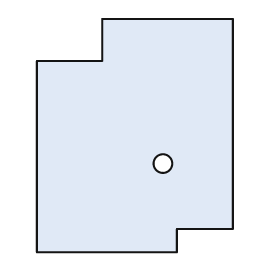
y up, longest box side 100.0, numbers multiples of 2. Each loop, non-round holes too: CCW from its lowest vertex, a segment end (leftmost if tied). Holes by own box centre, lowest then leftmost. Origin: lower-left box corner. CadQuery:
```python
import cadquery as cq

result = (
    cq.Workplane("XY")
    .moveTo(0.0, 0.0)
    .lineTo(60.0, 0.0)
    .lineTo(60.0, 10.0)
    .lineTo(84.0, 10.0)
    .lineTo(84.0, 100.0)
    .lineTo(28.0, 100.0)
    .lineTo(28.0, 82.0)
    .lineTo(0.0, 82.0)
    .close()
    .moveTo(54.0, 38.0)
    .circle(4.0)
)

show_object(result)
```